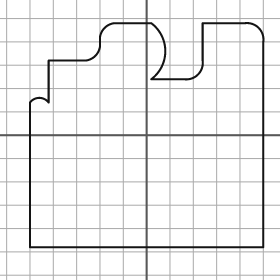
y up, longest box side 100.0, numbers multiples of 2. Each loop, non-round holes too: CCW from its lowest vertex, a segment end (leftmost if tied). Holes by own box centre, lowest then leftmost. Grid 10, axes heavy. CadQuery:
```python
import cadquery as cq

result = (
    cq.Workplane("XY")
    .moveTo(-50.0, -48.0)
    .lineTo(50.0, -48.0)
    .lineTo(50.0, 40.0)
    .threePointArc((48.0, 46.0), (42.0, 48.0))
    .lineTo(24.0, 48.0)
    .lineTo(24.0, 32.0)
    .threePointArc((22.0, 26.0), (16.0, 24.0))
    .lineTo(2.0, 24.0)
    .threePointArc((8.0, 36.0), (2.0, 48.0))
    .lineTo(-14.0, 48.0)
    .threePointArc((-18.0, 46.0), (-20.0, 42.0))
    .lineTo(-20.0, 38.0)
    .threePointArc((-22.0, 34.0), (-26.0, 32.0))
    .lineTo(-42.0, 32.0)
    .lineTo(-42.0, 14.0)
    .threePointArc((-46.0, 16.0), (-50.0, 14.0))
    .close()
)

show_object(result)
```